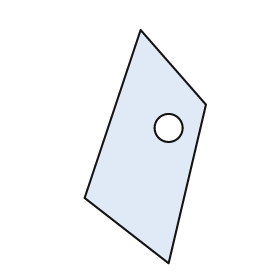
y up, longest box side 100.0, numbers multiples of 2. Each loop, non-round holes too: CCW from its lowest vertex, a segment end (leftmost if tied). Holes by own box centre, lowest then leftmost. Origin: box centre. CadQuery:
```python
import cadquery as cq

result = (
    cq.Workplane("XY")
    .moveTo(10.0, -50.0)
    .lineTo(26.0, 18.0)
    .lineTo(-2.0, 50.0)
    .lineTo(-26.0, -22.0)
    .close()
    .moveTo(10.0, 8.0)
    .circle(6.0)
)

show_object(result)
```